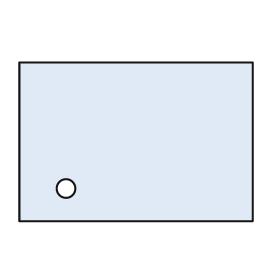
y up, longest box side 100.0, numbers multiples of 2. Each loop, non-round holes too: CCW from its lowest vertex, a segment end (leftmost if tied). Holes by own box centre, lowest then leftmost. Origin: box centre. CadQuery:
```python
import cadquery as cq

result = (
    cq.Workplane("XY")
    .moveTo(-50.0, -34.0)
    .lineTo(50.0, -34.0)
    .lineTo(50.0, 34.0)
    .lineTo(-50.0, 34.0)
    .close()
    .moveTo(-30.0, -20.0)
    .circle(4.0)
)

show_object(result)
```